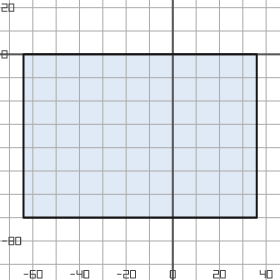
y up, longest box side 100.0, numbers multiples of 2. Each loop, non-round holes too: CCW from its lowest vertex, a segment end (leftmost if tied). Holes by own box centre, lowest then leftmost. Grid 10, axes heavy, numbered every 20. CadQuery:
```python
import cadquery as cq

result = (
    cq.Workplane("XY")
    .moveTo(-64.0, -70.0)
    .lineTo(36.0, -70.0)
    .lineTo(36.0, 0.0)
    .lineTo(-64.0, 0.0)
    .close()
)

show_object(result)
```